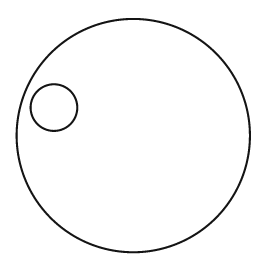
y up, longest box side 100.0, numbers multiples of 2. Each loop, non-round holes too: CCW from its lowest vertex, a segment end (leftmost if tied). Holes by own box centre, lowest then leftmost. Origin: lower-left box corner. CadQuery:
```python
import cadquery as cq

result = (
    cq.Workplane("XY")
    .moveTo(50.0, 50.0)
    .circle(50.0)
    .moveTo(16.0, 62.0)
    .circle(10.0)
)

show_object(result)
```